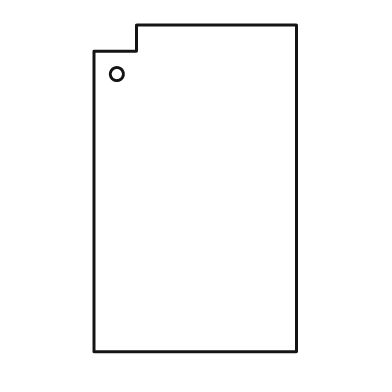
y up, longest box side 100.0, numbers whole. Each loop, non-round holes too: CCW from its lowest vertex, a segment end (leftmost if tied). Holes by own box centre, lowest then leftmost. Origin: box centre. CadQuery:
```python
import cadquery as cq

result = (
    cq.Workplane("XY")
    .moveTo(-31.0, -50.0)
    .lineTo(31.0, -50.0)
    .lineTo(31.0, 50.0)
    .lineTo(-18.0, 50.0)
    .lineTo(-18.0, 42.0)
    .lineTo(-31.0, 42.0)
    .close()
    .moveTo(-24.0, 35.0)
    .circle(2.0)
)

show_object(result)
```